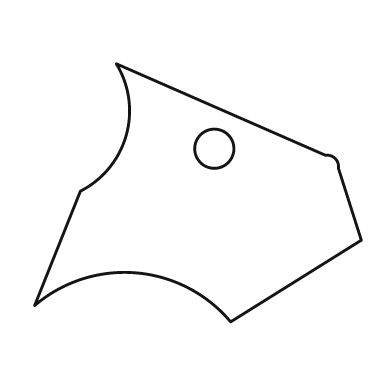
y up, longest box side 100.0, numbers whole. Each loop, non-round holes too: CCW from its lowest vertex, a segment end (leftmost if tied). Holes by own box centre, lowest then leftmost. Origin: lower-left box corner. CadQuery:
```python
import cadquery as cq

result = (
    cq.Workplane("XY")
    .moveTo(60.0, 0.0)
    .lineTo(100.0, 25.0)
    .lineTo(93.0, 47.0)
    .threePointArc((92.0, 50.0), (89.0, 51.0))
    .lineTo(25.0, 79.0)
    .threePointArc((28.0, 57.0), (14.0, 40.0))
    .lineTo(0.0, 5.0)
    .threePointArc((31.0, 15.0), (60.0, 0.0))
    .close()
    .moveTo(55.0, 53.0)
    .circle(6.0)
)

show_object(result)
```